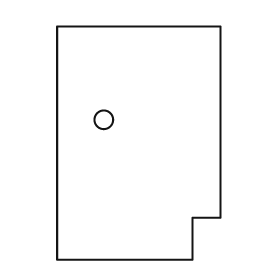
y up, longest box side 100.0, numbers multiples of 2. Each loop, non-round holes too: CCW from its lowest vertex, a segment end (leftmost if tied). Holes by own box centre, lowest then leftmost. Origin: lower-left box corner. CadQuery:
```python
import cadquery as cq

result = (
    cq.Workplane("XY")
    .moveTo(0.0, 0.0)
    .lineTo(58.0, 0.0)
    .lineTo(58.0, 18.0)
    .lineTo(70.0, 18.0)
    .lineTo(70.0, 100.0)
    .lineTo(0.0, 100.0)
    .close()
    .moveTo(20.0, 60.0)
    .circle(4.0)
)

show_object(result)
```